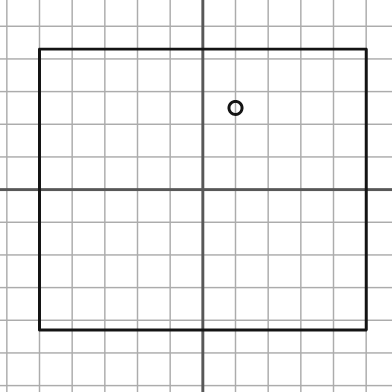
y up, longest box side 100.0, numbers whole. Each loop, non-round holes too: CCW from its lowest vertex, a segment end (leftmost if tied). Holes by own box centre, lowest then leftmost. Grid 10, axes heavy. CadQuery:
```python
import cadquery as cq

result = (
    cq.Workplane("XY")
    .moveTo(-50.0, -43.0)
    .lineTo(50.0, -43.0)
    .lineTo(50.0, 43.0)
    .lineTo(-50.0, 43.0)
    .close()
    .moveTo(10.0, 25.0)
    .circle(2.0)
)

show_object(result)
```